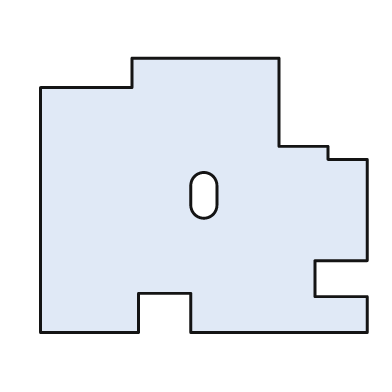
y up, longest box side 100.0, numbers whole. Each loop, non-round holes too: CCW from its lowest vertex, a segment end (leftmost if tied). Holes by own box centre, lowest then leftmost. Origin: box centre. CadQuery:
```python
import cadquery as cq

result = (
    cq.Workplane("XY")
    .moveTo(-50.0, -42.0)
    .lineTo(-20.0, -42.0)
    .lineTo(-20.0, -30.0)
    .lineTo(-4.0, -30.0)
    .lineTo(-4.0, -42.0)
    .lineTo(50.0, -42.0)
    .lineTo(50.0, -31.0)
    .lineTo(34.0, -31.0)
    .lineTo(34.0, -20.0)
    .lineTo(50.0, -20.0)
    .lineTo(50.0, 11.0)
    .lineTo(38.0, 11.0)
    .lineTo(38.0, 15.0)
    .lineTo(23.0, 15.0)
    .lineTo(23.0, 42.0)
    .lineTo(-22.0, 42.0)
    .lineTo(-22.0, 33.0)
    .lineTo(-50.0, 33.0)
    .close()
    .moveTo(-4.0, -3.0)
    .threePointArc((0.0, -7.0), (4.0, -3.0))
    .lineTo(4.0, 3.0)
    .threePointArc((0.0, 7.0), (-4.0, 3.0))
    .close()
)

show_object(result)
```